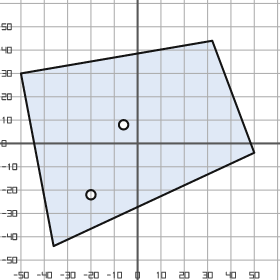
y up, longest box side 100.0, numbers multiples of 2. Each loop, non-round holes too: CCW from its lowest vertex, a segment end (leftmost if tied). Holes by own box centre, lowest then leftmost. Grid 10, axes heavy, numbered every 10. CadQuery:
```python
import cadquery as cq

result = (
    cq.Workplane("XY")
    .moveTo(-36.0, -44.0)
    .lineTo(50.0, -4.0)
    .lineTo(32.0, 44.0)
    .lineTo(-50.0, 30.0)
    .close()
    .moveTo(-20.0, -22.0)
    .circle(2.0)
    .moveTo(-6.0, 8.0)
    .circle(2.0)
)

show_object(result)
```